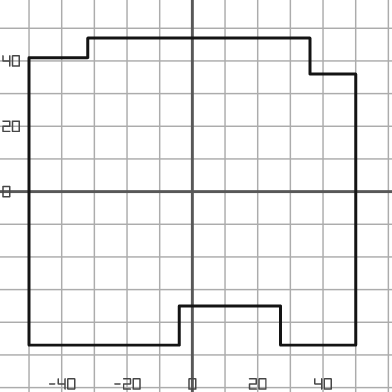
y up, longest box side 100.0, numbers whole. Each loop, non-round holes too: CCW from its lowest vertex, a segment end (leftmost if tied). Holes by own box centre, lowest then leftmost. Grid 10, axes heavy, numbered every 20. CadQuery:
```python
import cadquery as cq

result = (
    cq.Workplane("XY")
    .moveTo(-50.0, -47.0)
    .lineTo(-4.0, -47.0)
    .lineTo(-4.0, -35.0)
    .lineTo(27.0, -35.0)
    .lineTo(27.0, -47.0)
    .lineTo(50.0, -47.0)
    .lineTo(50.0, 36.0)
    .lineTo(36.0, 36.0)
    .lineTo(36.0, 47.0)
    .lineTo(-32.0, 47.0)
    .lineTo(-32.0, 41.0)
    .lineTo(-50.0, 41.0)
    .close()
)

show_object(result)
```